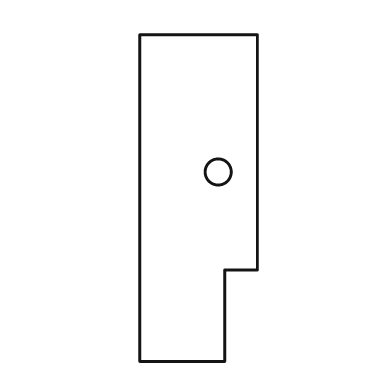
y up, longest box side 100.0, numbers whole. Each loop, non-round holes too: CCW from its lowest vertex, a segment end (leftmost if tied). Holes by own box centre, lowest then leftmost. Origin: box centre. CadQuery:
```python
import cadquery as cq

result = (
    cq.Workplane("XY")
    .moveTo(-18.0, -50.0)
    .lineTo(8.0, -50.0)
    .lineTo(8.0, -22.0)
    .lineTo(18.0, -22.0)
    .lineTo(18.0, 50.0)
    .lineTo(-18.0, 50.0)
    .close()
    .moveTo(6.0, 8.0)
    .circle(4.0)
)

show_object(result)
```